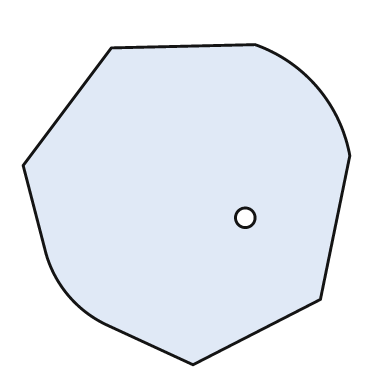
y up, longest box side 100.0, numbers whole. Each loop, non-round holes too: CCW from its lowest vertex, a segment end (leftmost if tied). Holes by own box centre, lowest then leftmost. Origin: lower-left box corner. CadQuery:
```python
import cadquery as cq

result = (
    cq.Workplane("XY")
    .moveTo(52.0, 0.0)
    .lineTo(91.0, 20.0)
    .lineTo(100.0, 64.0)
    .threePointArc((90.0, 85.0), (71.0, 98.0))
    .lineTo(27.0, 97.0)
    .lineTo(0.0, 61.0)
    .lineTo(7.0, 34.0)
    .threePointArc((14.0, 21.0), (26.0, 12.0))
    .close()
    .moveTo(68.0, 45.0)
    .circle(3.0)
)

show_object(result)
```